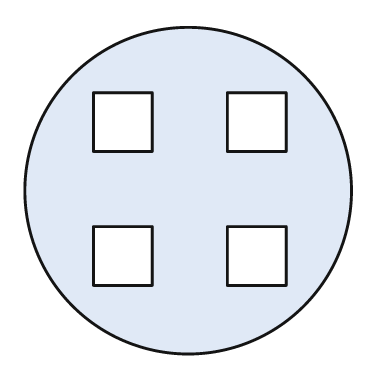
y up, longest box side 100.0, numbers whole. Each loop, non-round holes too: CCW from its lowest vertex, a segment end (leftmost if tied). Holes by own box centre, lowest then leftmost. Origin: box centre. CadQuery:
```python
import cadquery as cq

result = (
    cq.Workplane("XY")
    .moveTo(0.0, 0.0)
    .circle(50.0)
    .moveTo(-29.0, -29.0)
    .lineTo(-11.0, -29.0)
    .lineTo(-11.0, -11.0)
    .lineTo(-29.0, -11.0)
    .close()
    .moveTo(12.0, -29.0)
    .lineTo(30.0, -29.0)
    .lineTo(30.0, -11.0)
    .lineTo(12.0, -11.0)
    .close()
    .moveTo(-29.0, 12.0)
    .lineTo(-11.0, 12.0)
    .lineTo(-11.0, 30.0)
    .lineTo(-29.0, 30.0)
    .close()
    .moveTo(12.0, 12.0)
    .lineTo(30.0, 12.0)
    .lineTo(30.0, 30.0)
    .lineTo(12.0, 30.0)
    .close()
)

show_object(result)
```